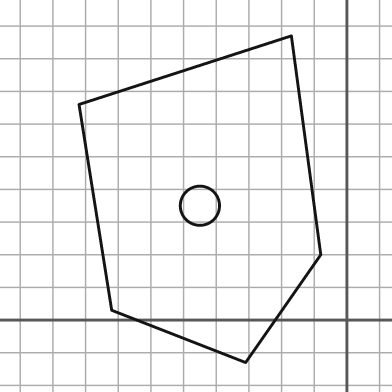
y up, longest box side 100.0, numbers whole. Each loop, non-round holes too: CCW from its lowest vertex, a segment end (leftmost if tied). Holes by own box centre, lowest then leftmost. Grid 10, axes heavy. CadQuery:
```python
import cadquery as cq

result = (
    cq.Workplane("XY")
    .moveTo(-31.0, -13.0)
    .lineTo(-8.0, 20.0)
    .lineTo(-17.0, 87.0)
    .lineTo(-82.0, 66.0)
    .lineTo(-72.0, 3.0)
    .close()
    .moveTo(-45.0, 35.0)
    .circle(6.0)
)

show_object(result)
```